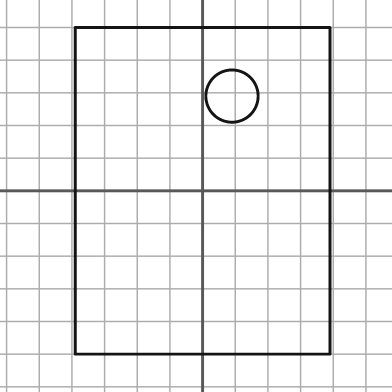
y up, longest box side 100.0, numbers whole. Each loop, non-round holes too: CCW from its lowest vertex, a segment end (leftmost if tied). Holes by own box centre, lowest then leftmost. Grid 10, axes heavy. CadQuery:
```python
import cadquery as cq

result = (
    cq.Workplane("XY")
    .moveTo(-39.0, -50.0)
    .lineTo(39.0, -50.0)
    .lineTo(39.0, 50.0)
    .lineTo(-39.0, 50.0)
    .close()
    .moveTo(9.0, 29.0)
    .circle(8.0)
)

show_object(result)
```